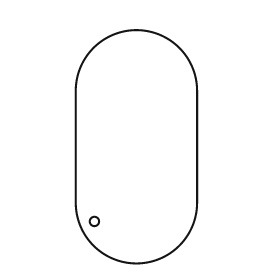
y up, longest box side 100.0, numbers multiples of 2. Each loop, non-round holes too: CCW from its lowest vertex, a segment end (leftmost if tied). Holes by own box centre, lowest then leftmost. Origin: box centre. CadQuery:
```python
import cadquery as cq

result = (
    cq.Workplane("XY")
    .moveTo(-26.0, -24.0)
    .threePointArc((0.0, -50.0), (26.0, -24.0))
    .lineTo(26.0, 24.0)
    .threePointArc((0.0, 50.0), (-26.0, 24.0))
    .close()
    .moveTo(-18.0, -32.0)
    .circle(2.0)
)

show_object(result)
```